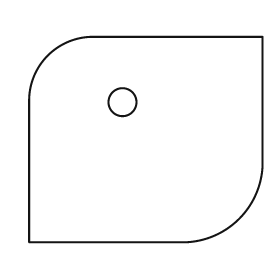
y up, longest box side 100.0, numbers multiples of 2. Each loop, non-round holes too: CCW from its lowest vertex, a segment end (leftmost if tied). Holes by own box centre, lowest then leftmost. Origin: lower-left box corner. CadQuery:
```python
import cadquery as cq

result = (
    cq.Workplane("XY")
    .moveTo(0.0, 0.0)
    .lineTo(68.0, 0.0)
    .threePointArc((90.0, 10.0), (100.0, 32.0))
    .lineTo(100.0, 88.0)
    .lineTo(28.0, 88.0)
    .threePointArc((8.0, 80.0), (0.0, 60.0))
    .close()
    .moveTo(40.0, 60.0)
    .circle(6.0)
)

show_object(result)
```